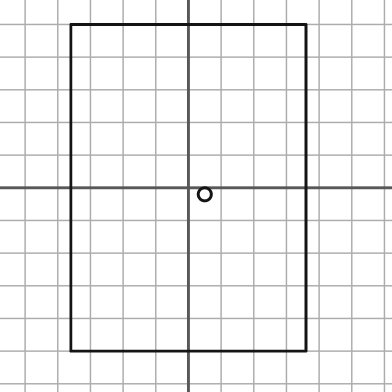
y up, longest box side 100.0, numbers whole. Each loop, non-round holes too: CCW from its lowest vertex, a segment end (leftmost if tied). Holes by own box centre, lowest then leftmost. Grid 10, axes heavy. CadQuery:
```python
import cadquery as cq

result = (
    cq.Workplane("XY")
    .moveTo(-36.0, -50.0)
    .lineTo(36.0, -50.0)
    .lineTo(36.0, 50.0)
    .lineTo(-36.0, 50.0)
    .close()
    .moveTo(5.0, -2.0)
    .circle(2.0)
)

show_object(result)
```